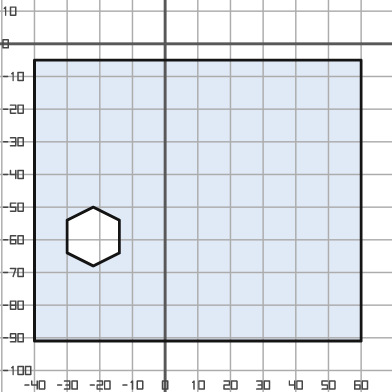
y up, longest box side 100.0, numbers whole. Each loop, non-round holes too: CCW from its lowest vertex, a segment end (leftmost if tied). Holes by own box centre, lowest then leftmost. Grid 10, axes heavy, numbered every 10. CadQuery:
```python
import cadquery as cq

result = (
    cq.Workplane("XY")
    .moveTo(-40.0, -91.0)
    .lineTo(60.0, -91.0)
    .lineTo(60.0, -5.0)
    .lineTo(-40.0, -5.0)
    .close()
    .moveTo(-22.0, -68.0)
    .lineTo(-14.0, -64.0)
    .lineTo(-14.0, -54.0)
    .lineTo(-22.0, -50.0)
    .lineTo(-30.0, -54.0)
    .lineTo(-30.0, -64.0)
    .close()
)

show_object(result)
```